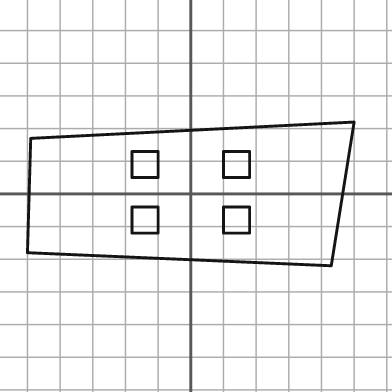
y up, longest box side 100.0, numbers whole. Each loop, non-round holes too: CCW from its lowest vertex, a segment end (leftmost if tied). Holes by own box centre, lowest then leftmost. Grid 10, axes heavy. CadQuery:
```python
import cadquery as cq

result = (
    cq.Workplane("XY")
    .moveTo(43.0, -22.0)
    .lineTo(50.0, 22.0)
    .lineTo(-49.0, 17.0)
    .lineTo(-50.0, -18.0)
    .close()
    .moveTo(-18.0, -12.0)
    .lineTo(-10.0, -12.0)
    .lineTo(-10.0, -4.0)
    .lineTo(-18.0, -4.0)
    .close()
    .moveTo(10.0, -12.0)
    .lineTo(18.0, -12.0)
    .lineTo(18.0, -4.0)
    .lineTo(10.0, -4.0)
    .close()
    .moveTo(-18.0, 5.0)
    .lineTo(-10.0, 5.0)
    .lineTo(-10.0, 13.0)
    .lineTo(-18.0, 13.0)
    .close()
    .moveTo(10.0, 5.0)
    .lineTo(18.0, 5.0)
    .lineTo(18.0, 13.0)
    .lineTo(10.0, 13.0)
    .close()
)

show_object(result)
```